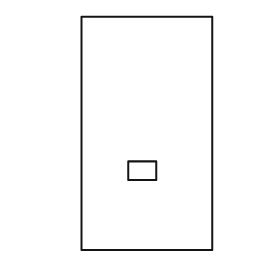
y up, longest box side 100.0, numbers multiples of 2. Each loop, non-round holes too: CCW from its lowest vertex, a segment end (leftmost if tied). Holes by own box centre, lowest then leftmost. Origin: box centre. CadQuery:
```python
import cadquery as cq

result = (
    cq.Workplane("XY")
    .moveTo(-28.0, -50.0)
    .lineTo(28.0, -50.0)
    .lineTo(28.0, 50.0)
    .lineTo(-28.0, 50.0)
    .close()
    .moveTo(-8.0, -20.0)
    .lineTo(4.0, -20.0)
    .lineTo(4.0, -12.0)
    .lineTo(-8.0, -12.0)
    .close()
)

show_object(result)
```